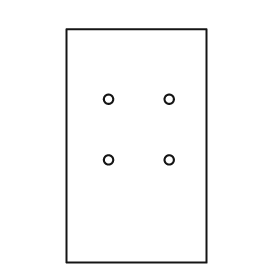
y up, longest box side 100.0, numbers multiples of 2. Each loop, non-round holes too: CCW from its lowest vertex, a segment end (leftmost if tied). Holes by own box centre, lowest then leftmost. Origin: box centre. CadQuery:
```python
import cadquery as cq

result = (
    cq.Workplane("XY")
    .moveTo(-30.0, -50.0)
    .lineTo(30.0, -50.0)
    .lineTo(30.0, 50.0)
    .lineTo(-30.0, 50.0)
    .close()
    .moveTo(-12.0, -6.0)
    .circle(2.0)
    .moveTo(14.0, -6.0)
    .circle(2.0)
    .moveTo(-12.0, 20.0)
    .circle(2.0)
    .moveTo(14.0, 20.0)
    .circle(2.0)
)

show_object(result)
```